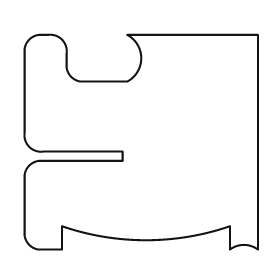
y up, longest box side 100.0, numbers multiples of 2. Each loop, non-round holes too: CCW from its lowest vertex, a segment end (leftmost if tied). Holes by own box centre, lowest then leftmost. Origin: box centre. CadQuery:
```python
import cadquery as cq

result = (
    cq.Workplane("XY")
    .moveTo(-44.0, -46.0)
    .lineTo(-34.0, -46.0)
    .lineTo(-34.0, -36.0)
    .threePointArc((2.0, -42.0), (38.0, -36.0))
    .lineTo(38.0, -46.0)
    .threePointArc((44.0, -44.0), (50.0, -46.0))
    .lineTo(50.0, 46.0)
    .lineTo(-6.0, 46.0)
    .threePointArc((0.0, 36.0), (-6.0, 26.0))
    .lineTo(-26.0, 26.0)
    .threePointArc((-30.0, 28.0), (-32.0, 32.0))
    .lineTo(-32.0, 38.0)
    .threePointArc((-34.0, 44.0), (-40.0, 46.0))
    .lineTo(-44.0, 46.0)
    .threePointArc((-48.0, 44.0), (-50.0, 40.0))
    .lineTo(-50.0, 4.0)
    .threePointArc((-48.0, -2.0), (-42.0, -4.0))
    .lineTo(-8.0, -4.0)
    .lineTo(-8.0, -8.0)
    .lineTo(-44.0, -8.0)
    .threePointArc((-48.0, -10.0), (-50.0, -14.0))
    .lineTo(-50.0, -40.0)
    .threePointArc((-48.0, -44.0), (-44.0, -46.0))
    .close()
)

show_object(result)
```